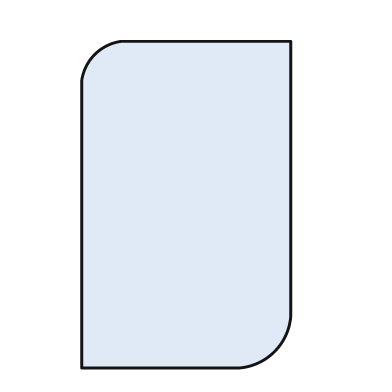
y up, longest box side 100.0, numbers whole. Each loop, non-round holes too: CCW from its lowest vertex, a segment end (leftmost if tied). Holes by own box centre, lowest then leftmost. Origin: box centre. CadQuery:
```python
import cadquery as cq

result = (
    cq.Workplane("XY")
    .moveTo(-32.0, -50.0)
    .lineTo(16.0, -50.0)
    .threePointArc((27.0, -45.0), (32.0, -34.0))
    .lineTo(32.0, 50.0)
    .lineTo(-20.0, 50.0)
    .threePointArc((-28.0, 46.0), (-32.0, 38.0))
    .close()
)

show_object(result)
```